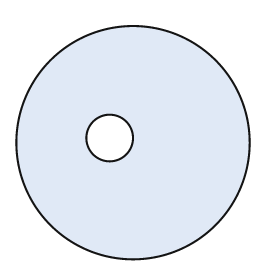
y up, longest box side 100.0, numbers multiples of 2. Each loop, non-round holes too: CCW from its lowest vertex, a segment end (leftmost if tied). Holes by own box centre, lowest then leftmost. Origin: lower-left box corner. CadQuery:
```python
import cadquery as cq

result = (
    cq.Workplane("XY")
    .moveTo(50.0, 50.0)
    .circle(50.0)
    .moveTo(40.0, 52.0)
    .circle(10.0)
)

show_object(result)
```